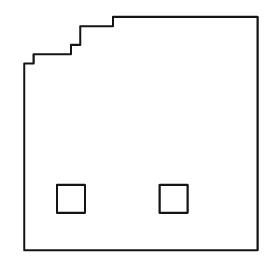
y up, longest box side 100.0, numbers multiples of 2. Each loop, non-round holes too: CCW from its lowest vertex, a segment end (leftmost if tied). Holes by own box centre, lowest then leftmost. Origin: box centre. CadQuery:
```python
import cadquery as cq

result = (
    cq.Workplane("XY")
    .moveTo(-50.0, -50.0)
    .lineTo(50.0, -50.0)
    .lineTo(50.0, 50.0)
    .lineTo(-12.0, 50.0)
    .lineTo(-12.0, 46.0)
    .lineTo(-26.0, 46.0)
    .lineTo(-26.0, 38.0)
    .lineTo(-30.0, 38.0)
    .lineTo(-30.0, 34.0)
    .lineTo(-46.0, 34.0)
    .lineTo(-46.0, 30.0)
    .lineTo(-50.0, 30.0)
    .close()
    .moveTo(-36.0, -34.0)
    .lineTo(-24.0, -34.0)
    .lineTo(-24.0, -22.0)
    .lineTo(-36.0, -22.0)
    .close()
    .moveTo(8.0, -34.0)
    .lineTo(20.0, -34.0)
    .lineTo(20.0, -22.0)
    .lineTo(8.0, -22.0)
    .close()
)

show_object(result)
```